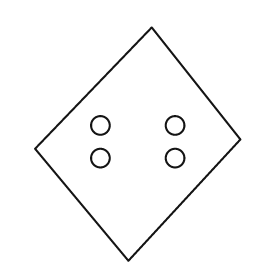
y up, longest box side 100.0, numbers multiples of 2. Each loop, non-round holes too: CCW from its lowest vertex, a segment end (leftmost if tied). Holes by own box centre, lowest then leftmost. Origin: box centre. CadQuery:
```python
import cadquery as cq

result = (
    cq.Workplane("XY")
    .moveTo(-4.0, -50.0)
    .lineTo(44.0, 2.0)
    .lineTo(6.0, 50.0)
    .lineTo(-44.0, -2.0)
    .close()
    .moveTo(-16.0, -6.0)
    .circle(4.0)
    .moveTo(16.0, -6.0)
    .circle(4.0)
    .moveTo(-16.0, 8.0)
    .circle(4.0)
    .moveTo(16.0, 8.0)
    .circle(4.0)
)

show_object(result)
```